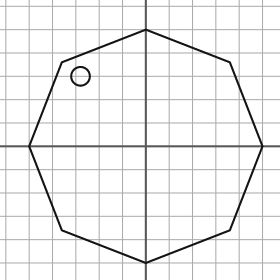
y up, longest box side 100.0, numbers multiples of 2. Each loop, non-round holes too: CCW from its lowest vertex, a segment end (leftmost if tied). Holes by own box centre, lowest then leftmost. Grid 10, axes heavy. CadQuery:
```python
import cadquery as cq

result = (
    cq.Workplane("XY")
    .moveTo(0.0, -50.0)
    .lineTo(36.0, -36.0)
    .lineTo(50.0, 0.0)
    .lineTo(36.0, 36.0)
    .lineTo(0.0, 50.0)
    .lineTo(-36.0, 36.0)
    .lineTo(-50.0, 0.0)
    .lineTo(-36.0, -36.0)
    .close()
    .moveTo(-28.0, 30.0)
    .circle(4.0)
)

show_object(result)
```